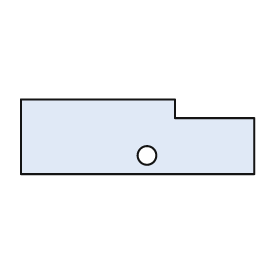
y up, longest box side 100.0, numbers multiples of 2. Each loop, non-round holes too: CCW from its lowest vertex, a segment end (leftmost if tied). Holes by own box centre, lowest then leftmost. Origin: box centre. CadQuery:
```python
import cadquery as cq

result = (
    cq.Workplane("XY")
    .moveTo(-50.0, -16.0)
    .lineTo(50.0, -16.0)
    .lineTo(50.0, 8.0)
    .lineTo(16.0, 8.0)
    .lineTo(16.0, 16.0)
    .lineTo(-50.0, 16.0)
    .close()
    .moveTo(4.0, -8.0)
    .circle(4.0)
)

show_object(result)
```